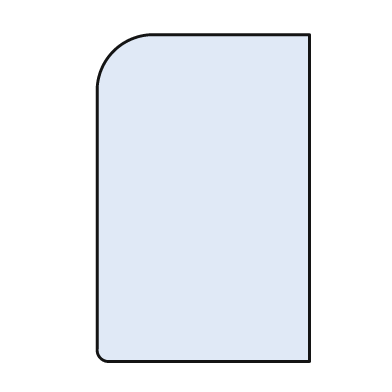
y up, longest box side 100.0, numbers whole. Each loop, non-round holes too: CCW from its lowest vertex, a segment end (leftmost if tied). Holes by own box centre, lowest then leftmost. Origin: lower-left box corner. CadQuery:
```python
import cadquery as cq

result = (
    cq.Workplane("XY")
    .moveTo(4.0, 0.0)
    .lineTo(65.0, 0.0)
    .lineTo(65.0, 100.0)
    .lineTo(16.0, 100.0)
    .threePointArc((5.0, 95.0), (0.0, 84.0))
    .lineTo(0.0, 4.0)
    .threePointArc((1.0, 1.0), (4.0, 0.0))
    .close()
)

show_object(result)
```